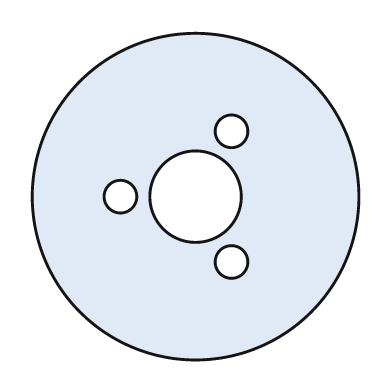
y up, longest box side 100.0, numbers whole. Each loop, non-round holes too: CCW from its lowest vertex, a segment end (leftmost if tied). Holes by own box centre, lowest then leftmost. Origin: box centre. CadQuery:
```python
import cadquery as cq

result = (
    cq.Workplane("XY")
    .moveTo(0.0, 0.0)
    .circle(50.0)
    .moveTo(11.0, -20.0)
    .circle(5.0)
    .moveTo(-23.0, 0.0)
    .circle(5.0)
    .moveTo(0.0, 0.0)
    .circle(14.0)
    .moveTo(11.0, 20.0)
    .circle(5.0)
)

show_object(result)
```